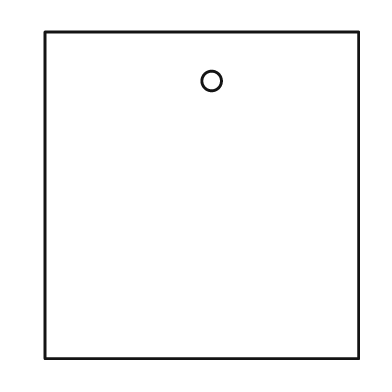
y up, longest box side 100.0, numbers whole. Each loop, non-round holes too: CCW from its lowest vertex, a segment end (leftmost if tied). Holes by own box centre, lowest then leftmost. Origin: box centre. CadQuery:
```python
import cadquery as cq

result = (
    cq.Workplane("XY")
    .moveTo(-48.0, -50.0)
    .lineTo(48.0, -50.0)
    .lineTo(48.0, 50.0)
    .lineTo(-48.0, 50.0)
    .close()
    .moveTo(3.0, 35.0)
    .circle(3.0)
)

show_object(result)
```